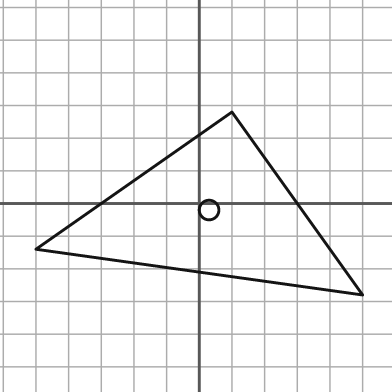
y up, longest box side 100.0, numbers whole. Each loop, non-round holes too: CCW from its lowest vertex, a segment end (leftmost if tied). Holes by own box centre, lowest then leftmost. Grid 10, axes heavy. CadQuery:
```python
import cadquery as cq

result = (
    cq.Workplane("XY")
    .moveTo(50.0, -28.0)
    .lineTo(10.0, 28.0)
    .lineTo(-50.0, -14.0)
    .close()
    .moveTo(3.0, -2.0)
    .circle(3.0)
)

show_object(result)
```